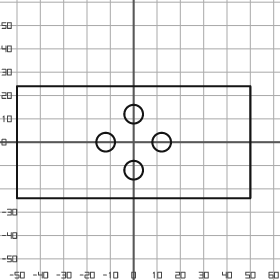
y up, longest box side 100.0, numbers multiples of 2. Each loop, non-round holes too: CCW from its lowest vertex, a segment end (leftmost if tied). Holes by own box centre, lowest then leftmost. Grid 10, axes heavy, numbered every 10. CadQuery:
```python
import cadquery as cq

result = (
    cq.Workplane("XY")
    .moveTo(-50.0, -24.0)
    .lineTo(50.0, -24.0)
    .lineTo(50.0, 24.0)
    .lineTo(-50.0, 24.0)
    .close()
    .moveTo(0.0, -12.0)
    .circle(4.0)
    .moveTo(-12.0, 0.0)
    .circle(4.0)
    .moveTo(12.0, 0.0)
    .circle(4.0)
    .moveTo(0.0, 12.0)
    .circle(4.0)
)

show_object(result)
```